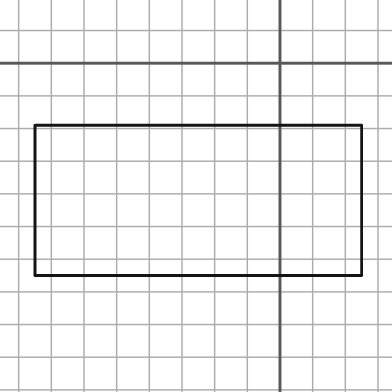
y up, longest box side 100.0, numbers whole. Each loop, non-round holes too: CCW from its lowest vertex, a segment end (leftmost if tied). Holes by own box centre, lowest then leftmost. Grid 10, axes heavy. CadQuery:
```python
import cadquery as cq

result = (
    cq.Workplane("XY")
    .moveTo(-75.0, -65.0)
    .lineTo(25.0, -65.0)
    .lineTo(25.0, -19.0)
    .lineTo(-75.0, -19.0)
    .close()
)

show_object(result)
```